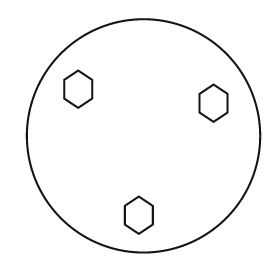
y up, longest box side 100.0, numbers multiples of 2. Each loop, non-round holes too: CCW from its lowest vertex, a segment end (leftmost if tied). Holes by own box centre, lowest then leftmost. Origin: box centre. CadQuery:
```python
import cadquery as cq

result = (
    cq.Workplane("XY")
    .moveTo(0.0, 0.0)
    .circle(50.0)
    .moveTo(-2.0, -42.0)
    .lineTo(4.0, -38.0)
    .lineTo(4.0, -30.0)
    .lineTo(-2.0, -26.0)
    .lineTo(-8.0, -30.0)
    .lineTo(-8.0, -38.0)
    .close()
    .moveTo(30.0, 6.0)
    .lineTo(36.0, 10.0)
    .lineTo(36.0, 18.0)
    .lineTo(30.0, 22.0)
    .lineTo(24.0, 18.0)
    .lineTo(24.0, 10.0)
    .close()
    .moveTo(-28.0, 12.0)
    .lineTo(-22.0, 16.0)
    .lineTo(-22.0, 24.0)
    .lineTo(-28.0, 28.0)
    .lineTo(-34.0, 24.0)
    .lineTo(-34.0, 16.0)
    .close()
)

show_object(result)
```